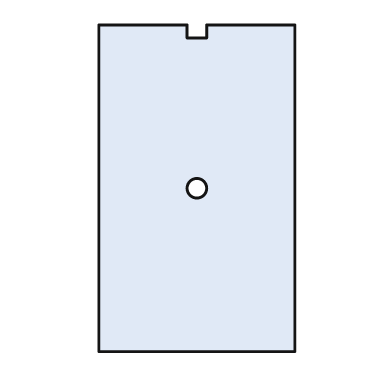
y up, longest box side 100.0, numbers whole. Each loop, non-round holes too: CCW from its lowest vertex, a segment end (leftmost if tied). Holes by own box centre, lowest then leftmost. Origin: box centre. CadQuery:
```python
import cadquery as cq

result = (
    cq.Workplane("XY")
    .moveTo(-30.0, -50.0)
    .lineTo(30.0, -50.0)
    .lineTo(30.0, 50.0)
    .lineTo(3.0, 50.0)
    .lineTo(3.0, 46.0)
    .lineTo(-3.0, 46.0)
    .lineTo(-3.0, 50.0)
    .lineTo(-30.0, 50.0)
    .close()
    .moveTo(0.0, 0.0)
    .circle(3.0)
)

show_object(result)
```